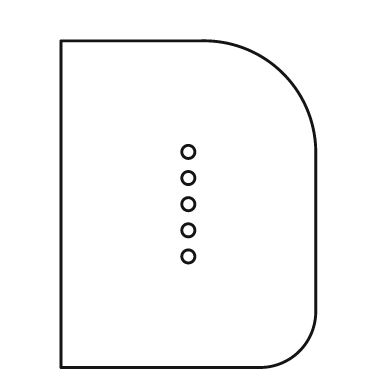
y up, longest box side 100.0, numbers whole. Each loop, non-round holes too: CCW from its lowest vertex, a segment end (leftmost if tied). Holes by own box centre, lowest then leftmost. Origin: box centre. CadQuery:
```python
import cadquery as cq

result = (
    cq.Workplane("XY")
    .moveTo(-39.0, -50.0)
    .lineTo(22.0, -50.0)
    .threePointArc((34.0, -45.0), (39.0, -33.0))
    .lineTo(39.0, 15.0)
    .threePointArc((29.0, 40.0), (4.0, 50.0))
    .lineTo(-39.0, 50.0)
    .close()
    .moveTo(0.0, -16.0)
    .circle(2.0)
    .moveTo(0.0, -8.0)
    .circle(2.0)
    .moveTo(0.0, 0.0)
    .circle(2.0)
    .moveTo(0.0, 8.0)
    .circle(2.0)
    .moveTo(0.0, 16.0)
    .circle(2.0)
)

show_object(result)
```